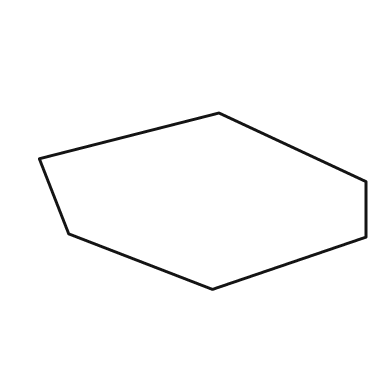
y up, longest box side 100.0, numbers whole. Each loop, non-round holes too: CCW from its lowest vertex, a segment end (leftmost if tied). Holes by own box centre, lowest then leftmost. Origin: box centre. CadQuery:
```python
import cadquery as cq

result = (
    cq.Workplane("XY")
    .moveTo(3.0, -27.0)
    .lineTo(50.0, -11.0)
    .lineTo(50.0, 6.0)
    .lineTo(5.0, 27.0)
    .lineTo(-50.0, 13.0)
    .lineTo(-41.0, -10.0)
    .close()
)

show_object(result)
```